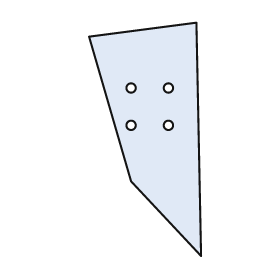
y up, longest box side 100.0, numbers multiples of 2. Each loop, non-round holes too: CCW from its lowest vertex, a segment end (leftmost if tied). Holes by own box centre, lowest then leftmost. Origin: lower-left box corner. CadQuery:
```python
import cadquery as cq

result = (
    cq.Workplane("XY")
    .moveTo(48.0, 0.0)
    .lineTo(46.0, 100.0)
    .lineTo(0.0, 94.0)
    .lineTo(18.0, 32.0)
    .close()
    .moveTo(18.0, 56.0)
    .circle(2.0)
    .moveTo(34.0, 56.0)
    .circle(2.0)
    .moveTo(18.0, 72.0)
    .circle(2.0)
    .moveTo(34.0, 72.0)
    .circle(2.0)
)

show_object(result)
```